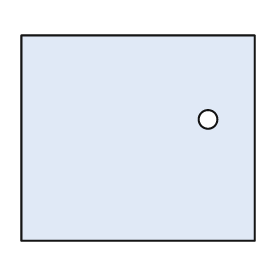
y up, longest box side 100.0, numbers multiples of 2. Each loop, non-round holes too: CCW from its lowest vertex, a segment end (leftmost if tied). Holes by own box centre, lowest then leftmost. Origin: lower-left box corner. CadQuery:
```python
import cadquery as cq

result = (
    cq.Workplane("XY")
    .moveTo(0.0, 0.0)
    .lineTo(100.0, 0.0)
    .lineTo(100.0, 88.0)
    .lineTo(0.0, 88.0)
    .close()
    .moveTo(80.0, 52.0)
    .circle(4.0)
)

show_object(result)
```